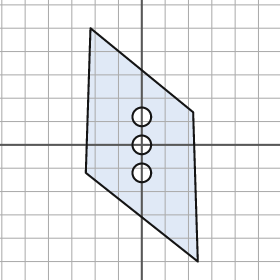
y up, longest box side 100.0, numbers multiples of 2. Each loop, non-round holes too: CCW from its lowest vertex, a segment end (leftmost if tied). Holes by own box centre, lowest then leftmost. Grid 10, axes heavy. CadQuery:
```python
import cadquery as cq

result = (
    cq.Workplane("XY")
    .moveTo(24.0, -50.0)
    .lineTo(22.0, 14.0)
    .lineTo(-22.0, 50.0)
    .lineTo(-24.0, -12.0)
    .close()
    .moveTo(0.0, -12.0)
    .circle(4.0)
    .moveTo(0.0, 0.0)
    .circle(4.0)
    .moveTo(0.0, 12.0)
    .circle(4.0)
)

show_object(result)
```